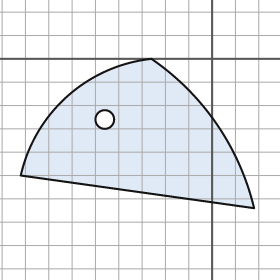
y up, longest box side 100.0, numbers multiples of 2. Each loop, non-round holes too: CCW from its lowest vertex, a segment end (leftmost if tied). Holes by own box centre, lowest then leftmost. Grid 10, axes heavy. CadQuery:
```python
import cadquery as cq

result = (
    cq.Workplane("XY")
    .moveTo(18.0, -64.0)
    .threePointArc((2.0, -28.0), (-26.0, 0.0))
    .threePointArc((-62.0, -16.0), (-82.0, -50.0))
    .close()
    .moveTo(-46.0, -26.0)
    .circle(4.0)
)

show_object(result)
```